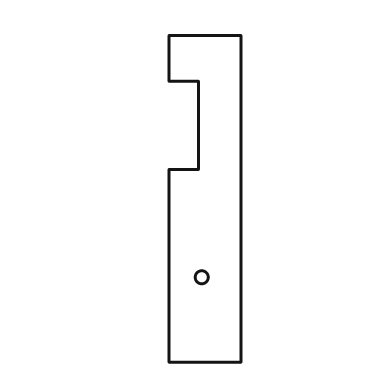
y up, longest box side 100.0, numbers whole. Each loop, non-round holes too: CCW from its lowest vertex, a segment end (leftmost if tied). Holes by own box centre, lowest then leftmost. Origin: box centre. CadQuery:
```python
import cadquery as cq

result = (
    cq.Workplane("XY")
    .moveTo(-11.0, -50.0)
    .lineTo(11.0, -50.0)
    .lineTo(11.0, 50.0)
    .lineTo(-11.0, 50.0)
    .lineTo(-11.0, 36.0)
    .lineTo(-2.0, 36.0)
    .lineTo(-2.0, 9.0)
    .lineTo(-11.0, 9.0)
    .close()
    .moveTo(-1.0, -24.0)
    .circle(2.0)
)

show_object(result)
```